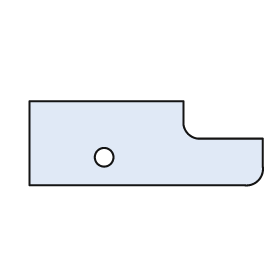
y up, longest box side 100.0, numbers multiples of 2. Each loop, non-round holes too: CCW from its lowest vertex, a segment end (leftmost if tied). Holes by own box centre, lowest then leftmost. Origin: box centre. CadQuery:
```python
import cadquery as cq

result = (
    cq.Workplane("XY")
    .moveTo(-50.0, -18.0)
    .lineTo(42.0, -18.0)
    .threePointArc((48.0, -16.0), (50.0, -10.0))
    .lineTo(50.0, 2.0)
    .lineTo(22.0, 2.0)
    .threePointArc((18.0, 4.0), (16.0, 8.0))
    .lineTo(16.0, 18.0)
    .lineTo(-50.0, 18.0)
    .close()
    .moveTo(-18.0, -6.0)
    .circle(4.0)
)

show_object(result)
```